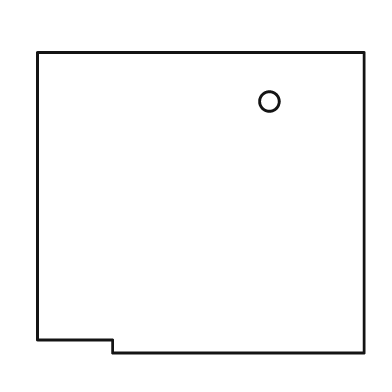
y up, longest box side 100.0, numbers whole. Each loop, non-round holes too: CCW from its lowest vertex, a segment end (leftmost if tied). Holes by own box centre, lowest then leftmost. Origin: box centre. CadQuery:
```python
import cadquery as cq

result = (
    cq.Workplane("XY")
    .moveTo(-27.0, -46.0)
    .lineTo(50.0, -46.0)
    .lineTo(50.0, 46.0)
    .lineTo(-50.0, 46.0)
    .lineTo(-50.0, -42.0)
    .lineTo(-27.0, -42.0)
    .close()
    .moveTo(21.0, 31.0)
    .circle(3.0)
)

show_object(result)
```